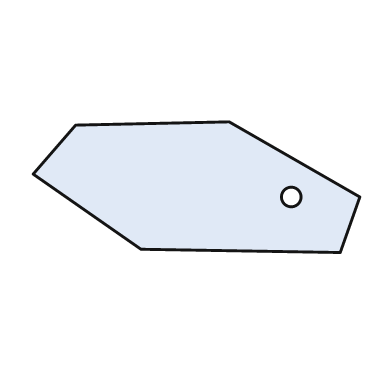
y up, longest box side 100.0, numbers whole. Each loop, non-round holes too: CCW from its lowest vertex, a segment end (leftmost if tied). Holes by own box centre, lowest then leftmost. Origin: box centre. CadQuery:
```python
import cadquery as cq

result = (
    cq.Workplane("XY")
    .moveTo(44.0, -20.0)
    .lineTo(50.0, -3.0)
    .lineTo(10.0, 20.0)
    .lineTo(-37.0, 19.0)
    .lineTo(-50.0, 4.0)
    .lineTo(-17.0, -19.0)
    .close()
    .moveTo(29.0, -3.0)
    .circle(3.0)
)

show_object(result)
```